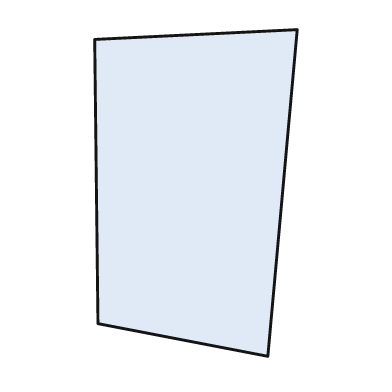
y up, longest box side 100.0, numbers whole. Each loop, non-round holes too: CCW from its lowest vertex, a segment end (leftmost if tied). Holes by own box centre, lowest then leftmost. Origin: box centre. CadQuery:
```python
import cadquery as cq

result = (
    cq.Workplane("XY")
    .moveTo(22.0, -50.0)
    .lineTo(31.0, 50.0)
    .lineTo(-31.0, 47.0)
    .lineTo(-30.0, -40.0)
    .close()
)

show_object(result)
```